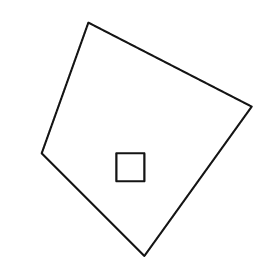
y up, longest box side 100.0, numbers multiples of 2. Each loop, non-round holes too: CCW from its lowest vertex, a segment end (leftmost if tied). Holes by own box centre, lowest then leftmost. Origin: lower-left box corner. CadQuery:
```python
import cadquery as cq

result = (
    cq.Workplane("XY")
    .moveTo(44.0, 0.0)
    .lineTo(90.0, 64.0)
    .lineTo(20.0, 100.0)
    .lineTo(0.0, 44.0)
    .close()
    .moveTo(32.0, 32.0)
    .lineTo(44.0, 32.0)
    .lineTo(44.0, 44.0)
    .lineTo(32.0, 44.0)
    .close()
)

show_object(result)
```